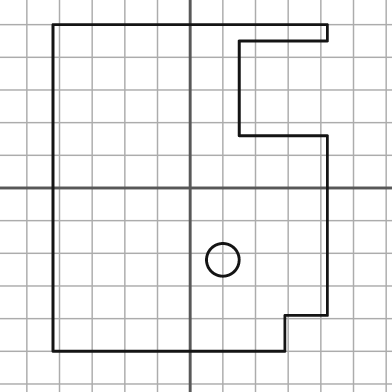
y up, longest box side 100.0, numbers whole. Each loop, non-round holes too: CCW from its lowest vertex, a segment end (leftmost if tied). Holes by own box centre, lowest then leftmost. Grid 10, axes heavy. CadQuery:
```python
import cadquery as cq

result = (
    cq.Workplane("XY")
    .moveTo(-42.0, -50.0)
    .lineTo(29.0, -50.0)
    .lineTo(29.0, -39.0)
    .lineTo(42.0, -39.0)
    .lineTo(42.0, 16.0)
    .lineTo(15.0, 16.0)
    .lineTo(15.0, 45.0)
    .lineTo(42.0, 45.0)
    .lineTo(42.0, 50.0)
    .lineTo(-42.0, 50.0)
    .close()
    .moveTo(10.0, -22.0)
    .circle(5.0)
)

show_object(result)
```